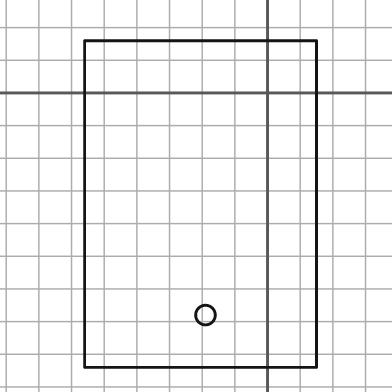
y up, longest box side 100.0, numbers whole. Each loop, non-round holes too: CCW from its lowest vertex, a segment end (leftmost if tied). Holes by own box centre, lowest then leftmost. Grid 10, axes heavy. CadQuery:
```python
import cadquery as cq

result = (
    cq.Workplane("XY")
    .moveTo(-56.0, -84.0)
    .lineTo(15.0, -84.0)
    .lineTo(15.0, 16.0)
    .lineTo(-56.0, 16.0)
    .close()
    .moveTo(-19.0, -68.0)
    .circle(3.0)
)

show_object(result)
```